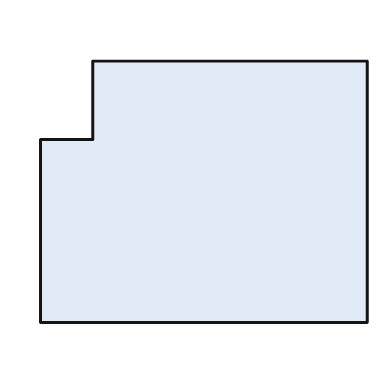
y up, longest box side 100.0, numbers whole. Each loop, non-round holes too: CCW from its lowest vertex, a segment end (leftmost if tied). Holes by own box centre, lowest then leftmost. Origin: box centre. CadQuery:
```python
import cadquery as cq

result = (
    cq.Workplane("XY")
    .moveTo(-50.0, -40.0)
    .lineTo(50.0, -40.0)
    .lineTo(50.0, 40.0)
    .lineTo(-34.0, 40.0)
    .lineTo(-34.0, 16.0)
    .lineTo(-50.0, 16.0)
    .close()
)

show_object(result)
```